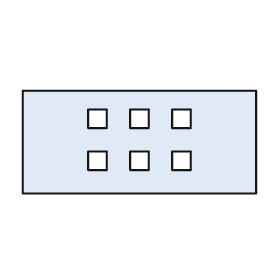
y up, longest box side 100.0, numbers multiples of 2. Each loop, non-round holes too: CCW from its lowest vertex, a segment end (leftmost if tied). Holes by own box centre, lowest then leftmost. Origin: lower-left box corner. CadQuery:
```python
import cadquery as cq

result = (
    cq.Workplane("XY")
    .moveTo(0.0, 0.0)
    .lineTo(100.0, 0.0)
    .lineTo(100.0, 44.0)
    .lineTo(0.0, 44.0)
    .close()
    .moveTo(28.0, 10.0)
    .lineTo(36.0, 10.0)
    .lineTo(36.0, 18.0)
    .lineTo(28.0, 18.0)
    .close()
    .moveTo(46.0, 10.0)
    .lineTo(54.0, 10.0)
    .lineTo(54.0, 18.0)
    .lineTo(46.0, 18.0)
    .close()
    .moveTo(64.0, 10.0)
    .lineTo(72.0, 10.0)
    .lineTo(72.0, 18.0)
    .lineTo(64.0, 18.0)
    .close()
    .moveTo(28.0, 28.0)
    .lineTo(36.0, 28.0)
    .lineTo(36.0, 36.0)
    .lineTo(28.0, 36.0)
    .close()
    .moveTo(46.0, 28.0)
    .lineTo(54.0, 28.0)
    .lineTo(54.0, 36.0)
    .lineTo(46.0, 36.0)
    .close()
    .moveTo(64.0, 28.0)
    .lineTo(72.0, 28.0)
    .lineTo(72.0, 36.0)
    .lineTo(64.0, 36.0)
    .close()
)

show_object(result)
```